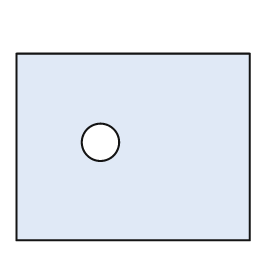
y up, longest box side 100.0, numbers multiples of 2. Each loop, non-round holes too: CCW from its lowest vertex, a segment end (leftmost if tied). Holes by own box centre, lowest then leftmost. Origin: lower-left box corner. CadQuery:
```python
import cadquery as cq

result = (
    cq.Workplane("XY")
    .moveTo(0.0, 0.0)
    .lineTo(100.0, 0.0)
    .lineTo(100.0, 80.0)
    .lineTo(0.0, 80.0)
    .close()
    .moveTo(36.0, 42.0)
    .circle(8.0)
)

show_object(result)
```